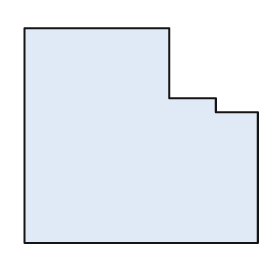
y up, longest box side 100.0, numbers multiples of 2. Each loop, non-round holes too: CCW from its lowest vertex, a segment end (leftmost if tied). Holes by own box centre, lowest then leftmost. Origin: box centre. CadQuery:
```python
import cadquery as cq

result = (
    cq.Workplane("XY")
    .moveTo(-50.0, -46.0)
    .lineTo(50.0, -46.0)
    .lineTo(50.0, 10.0)
    .lineTo(32.0, 10.0)
    .lineTo(32.0, 16.0)
    .lineTo(12.0, 16.0)
    .lineTo(12.0, 46.0)
    .lineTo(-50.0, 46.0)
    .close()
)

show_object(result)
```